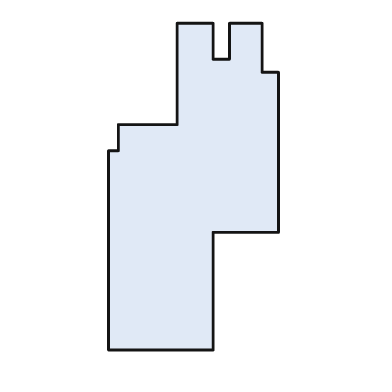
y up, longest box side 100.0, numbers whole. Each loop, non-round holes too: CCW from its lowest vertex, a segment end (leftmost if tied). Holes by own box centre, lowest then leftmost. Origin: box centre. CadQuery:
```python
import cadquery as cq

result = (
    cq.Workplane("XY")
    .moveTo(-26.0, -50.0)
    .lineTo(6.0, -50.0)
    .lineTo(6.0, -14.0)
    .lineTo(26.0, -14.0)
    .lineTo(26.0, 35.0)
    .lineTo(21.0, 35.0)
    .lineTo(21.0, 50.0)
    .lineTo(11.0, 50.0)
    .lineTo(11.0, 39.0)
    .lineTo(6.0, 39.0)
    .lineTo(6.0, 50.0)
    .lineTo(-5.0, 50.0)
    .lineTo(-5.0, 19.0)
    .lineTo(-23.0, 19.0)
    .lineTo(-23.0, 11.0)
    .lineTo(-26.0, 11.0)
    .close()
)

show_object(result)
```